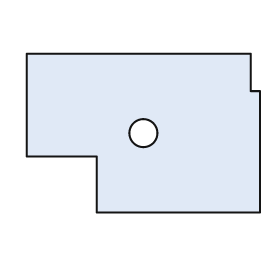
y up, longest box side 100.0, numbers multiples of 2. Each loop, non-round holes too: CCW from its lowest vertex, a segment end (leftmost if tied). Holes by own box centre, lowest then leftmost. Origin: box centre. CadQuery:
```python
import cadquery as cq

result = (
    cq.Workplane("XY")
    .moveTo(-20.0, -34.0)
    .lineTo(50.0, -34.0)
    .lineTo(50.0, 18.0)
    .lineTo(46.0, 18.0)
    .lineTo(46.0, 34.0)
    .lineTo(-50.0, 34.0)
    .lineTo(-50.0, -10.0)
    .lineTo(-20.0, -10.0)
    .close()
    .moveTo(0.0, 0.0)
    .circle(6.0)
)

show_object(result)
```